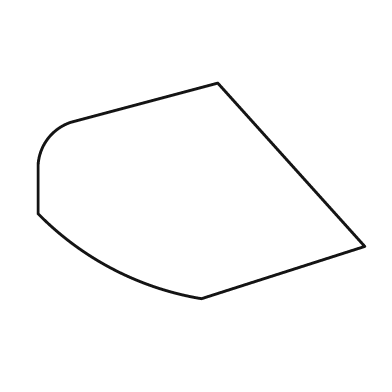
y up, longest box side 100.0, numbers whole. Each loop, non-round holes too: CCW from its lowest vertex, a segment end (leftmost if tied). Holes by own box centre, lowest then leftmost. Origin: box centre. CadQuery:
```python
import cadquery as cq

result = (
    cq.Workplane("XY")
    .moveTo(0.0, -33.0)
    .lineTo(50.0, -17.0)
    .lineTo(5.0, 33.0)
    .lineTo(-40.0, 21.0)
    .threePointArc((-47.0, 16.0), (-50.0, 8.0))
    .lineTo(-50.0, -7.0)
    .threePointArc((-27.0, -24.0), (0.0, -33.0))
    .close()
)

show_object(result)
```